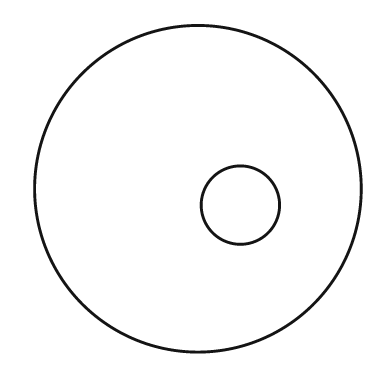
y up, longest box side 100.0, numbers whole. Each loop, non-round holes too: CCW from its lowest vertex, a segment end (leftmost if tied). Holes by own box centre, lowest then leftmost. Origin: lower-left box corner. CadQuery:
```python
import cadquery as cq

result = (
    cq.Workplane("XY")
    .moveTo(50.0, 50.0)
    .circle(50.0)
    .moveTo(63.0, 45.0)
    .circle(12.0)
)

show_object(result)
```